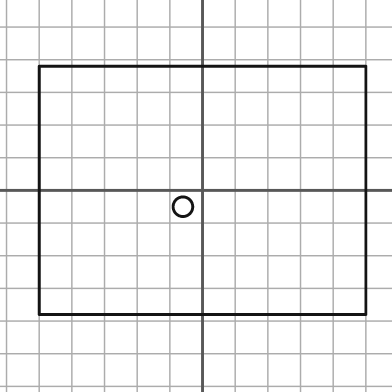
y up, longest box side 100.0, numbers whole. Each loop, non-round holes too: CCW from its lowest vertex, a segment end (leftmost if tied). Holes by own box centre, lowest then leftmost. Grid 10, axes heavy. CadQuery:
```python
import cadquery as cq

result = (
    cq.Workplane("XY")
    .moveTo(-50.0, -38.0)
    .lineTo(50.0, -38.0)
    .lineTo(50.0, 38.0)
    .lineTo(-50.0, 38.0)
    .close()
    .moveTo(-6.0, -5.0)
    .circle(3.0)
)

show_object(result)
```